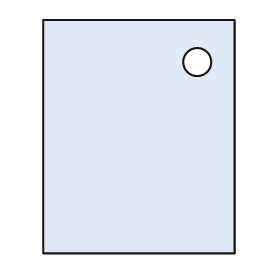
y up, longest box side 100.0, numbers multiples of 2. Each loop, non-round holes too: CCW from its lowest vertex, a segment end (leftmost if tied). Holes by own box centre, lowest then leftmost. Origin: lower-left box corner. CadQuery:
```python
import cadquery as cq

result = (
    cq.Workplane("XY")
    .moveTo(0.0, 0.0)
    .lineTo(82.0, 0.0)
    .lineTo(82.0, 100.0)
    .lineTo(0.0, 100.0)
    .close()
    .moveTo(66.0, 82.0)
    .circle(6.0)
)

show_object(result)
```